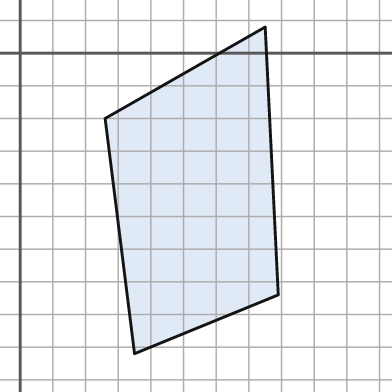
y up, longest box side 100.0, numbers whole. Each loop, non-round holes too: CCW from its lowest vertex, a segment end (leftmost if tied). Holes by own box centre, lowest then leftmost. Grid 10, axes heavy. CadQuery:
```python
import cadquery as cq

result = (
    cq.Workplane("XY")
    .moveTo(35.0, -92.0)
    .lineTo(79.0, -74.0)
    .lineTo(75.0, 8.0)
    .lineTo(26.0, -20.0)
    .close()
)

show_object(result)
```